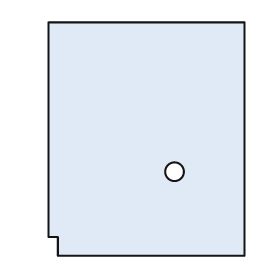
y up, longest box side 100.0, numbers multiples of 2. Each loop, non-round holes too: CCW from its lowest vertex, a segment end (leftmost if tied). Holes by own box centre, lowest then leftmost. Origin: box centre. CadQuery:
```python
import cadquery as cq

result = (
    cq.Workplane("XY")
    .moveTo(-38.0, -50.0)
    .lineTo(42.0, -50.0)
    .lineTo(42.0, 50.0)
    .lineTo(-42.0, 50.0)
    .lineTo(-42.0, -42.0)
    .lineTo(-38.0, -42.0)
    .close()
    .moveTo(12.0, -14.0)
    .circle(4.0)
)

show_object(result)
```